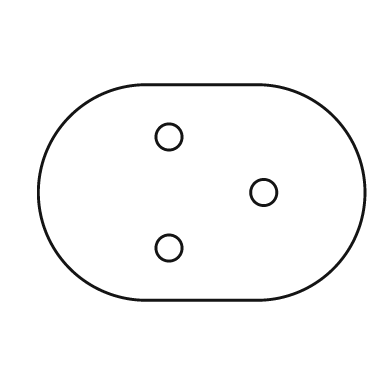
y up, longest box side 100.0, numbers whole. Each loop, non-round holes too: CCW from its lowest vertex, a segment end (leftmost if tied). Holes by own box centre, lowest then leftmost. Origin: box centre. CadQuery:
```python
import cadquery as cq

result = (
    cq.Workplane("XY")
    .moveTo(-17.0, -33.0)
    .lineTo(17.0, -33.0)
    .threePointArc((50.0, 0.0), (17.0, 33.0))
    .lineTo(-17.0, 33.0)
    .threePointArc((-50.0, 0.0), (-17.0, -33.0))
    .close()
    .moveTo(-10.0, -17.0)
    .circle(4.0)
    .moveTo(19.0, 0.0)
    .circle(4.0)
    .moveTo(-10.0, 17.0)
    .circle(4.0)
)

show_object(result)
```